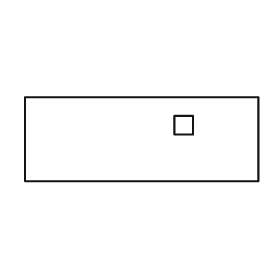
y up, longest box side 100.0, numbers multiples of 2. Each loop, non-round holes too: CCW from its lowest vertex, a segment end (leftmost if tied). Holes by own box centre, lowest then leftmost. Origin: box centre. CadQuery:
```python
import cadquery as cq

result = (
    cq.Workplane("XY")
    .moveTo(-50.0, -18.0)
    .lineTo(50.0, -18.0)
    .lineTo(50.0, 18.0)
    .lineTo(-50.0, 18.0)
    .close()
    .moveTo(14.0, 2.0)
    .lineTo(22.0, 2.0)
    .lineTo(22.0, 10.0)
    .lineTo(14.0, 10.0)
    .close()
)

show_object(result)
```